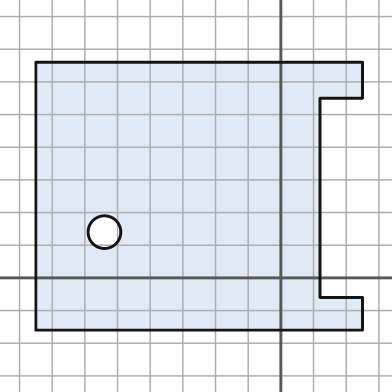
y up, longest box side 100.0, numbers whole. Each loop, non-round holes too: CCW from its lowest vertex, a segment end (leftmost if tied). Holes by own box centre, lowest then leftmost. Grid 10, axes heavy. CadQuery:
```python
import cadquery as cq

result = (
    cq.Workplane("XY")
    .moveTo(-75.0, -16.0)
    .lineTo(25.0, -16.0)
    .lineTo(25.0, -6.0)
    .lineTo(12.0, -6.0)
    .lineTo(12.0, 55.0)
    .lineTo(25.0, 55.0)
    .lineTo(25.0, 66.0)
    .lineTo(-75.0, 66.0)
    .close()
    .moveTo(-54.0, 14.0)
    .circle(5.0)
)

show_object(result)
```